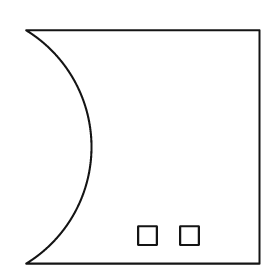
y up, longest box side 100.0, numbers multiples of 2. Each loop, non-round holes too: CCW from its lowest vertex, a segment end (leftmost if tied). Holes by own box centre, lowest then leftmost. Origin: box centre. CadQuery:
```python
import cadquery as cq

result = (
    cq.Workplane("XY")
    .moveTo(-50.0, -50.0)
    .lineTo(50.0, -50.0)
    .lineTo(50.0, 50.0)
    .lineTo(-50.0, 50.0)
    .threePointArc((-22.0, 0.0), (-50.0, -50.0))
    .close()
    .moveTo(-2.0, -42.0)
    .lineTo(6.0, -42.0)
    .lineTo(6.0, -34.0)
    .lineTo(-2.0, -34.0)
    .close()
    .moveTo(16.0, -42.0)
    .lineTo(24.0, -42.0)
    .lineTo(24.0, -34.0)
    .lineTo(16.0, -34.0)
    .close()
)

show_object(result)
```